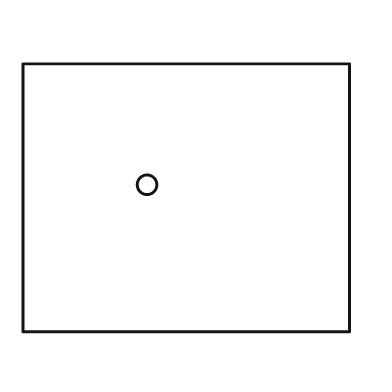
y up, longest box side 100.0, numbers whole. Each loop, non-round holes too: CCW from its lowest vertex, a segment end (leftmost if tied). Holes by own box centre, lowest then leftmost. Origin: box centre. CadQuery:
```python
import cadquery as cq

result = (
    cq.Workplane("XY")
    .moveTo(-50.0, -41.0)
    .lineTo(50.0, -41.0)
    .lineTo(50.0, 41.0)
    .lineTo(-50.0, 41.0)
    .close()
    .moveTo(-12.0, 4.0)
    .circle(3.0)
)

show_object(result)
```